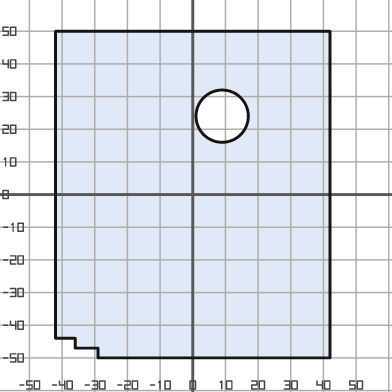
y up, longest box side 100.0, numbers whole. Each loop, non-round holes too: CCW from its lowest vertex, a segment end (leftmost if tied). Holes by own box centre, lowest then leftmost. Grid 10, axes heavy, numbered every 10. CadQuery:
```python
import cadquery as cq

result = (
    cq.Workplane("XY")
    .moveTo(-29.0, -50.0)
    .lineTo(42.0, -50.0)
    .lineTo(42.0, 50.0)
    .lineTo(-42.0, 50.0)
    .lineTo(-42.0, -44.0)
    .lineTo(-36.0, -44.0)
    .lineTo(-36.0, -47.0)
    .lineTo(-29.0, -47.0)
    .close()
    .moveTo(9.0, 24.0)
    .circle(8.0)
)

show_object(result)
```